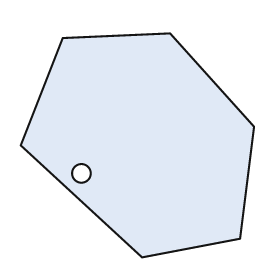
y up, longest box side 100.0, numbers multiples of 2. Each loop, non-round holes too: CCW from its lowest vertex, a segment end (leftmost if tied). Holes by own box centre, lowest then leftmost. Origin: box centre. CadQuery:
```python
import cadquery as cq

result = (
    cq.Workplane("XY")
    .moveTo(2.0, -48.0)
    .lineTo(44.0, -40.0)
    .lineTo(50.0, 8.0)
    .lineTo(14.0, 48.0)
    .lineTo(-32.0, 46.0)
    .lineTo(-50.0, 0.0)
    .close()
    .moveTo(-24.0, -12.0)
    .circle(4.0)
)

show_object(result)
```